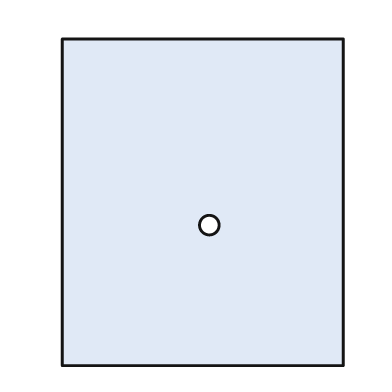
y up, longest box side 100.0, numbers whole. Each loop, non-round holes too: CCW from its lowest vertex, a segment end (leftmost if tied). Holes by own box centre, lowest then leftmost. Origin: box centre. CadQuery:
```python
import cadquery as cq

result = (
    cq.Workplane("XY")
    .moveTo(-43.0, -50.0)
    .lineTo(43.0, -50.0)
    .lineTo(43.0, 50.0)
    .lineTo(-43.0, 50.0)
    .close()
    .moveTo(2.0, -7.0)
    .circle(3.0)
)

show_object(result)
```